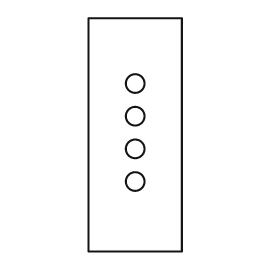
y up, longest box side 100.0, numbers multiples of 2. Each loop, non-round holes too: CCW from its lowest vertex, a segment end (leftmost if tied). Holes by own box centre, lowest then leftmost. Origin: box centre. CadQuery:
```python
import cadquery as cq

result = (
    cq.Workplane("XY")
    .moveTo(-20.0, -50.0)
    .lineTo(20.0, -50.0)
    .lineTo(20.0, 50.0)
    .lineTo(-20.0, 50.0)
    .close()
    .moveTo(0.0, -20.0)
    .circle(4.0)
    .moveTo(0.0, -6.0)
    .circle(4.0)
    .moveTo(0.0, 8.0)
    .circle(4.0)
    .moveTo(0.0, 22.0)
    .circle(4.0)
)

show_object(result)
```